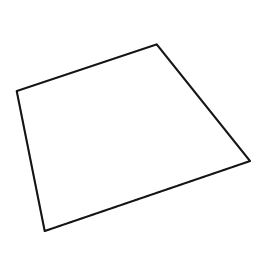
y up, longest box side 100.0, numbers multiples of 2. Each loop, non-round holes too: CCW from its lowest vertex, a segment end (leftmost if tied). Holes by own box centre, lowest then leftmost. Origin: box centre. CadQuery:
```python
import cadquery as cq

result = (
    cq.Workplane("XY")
    .moveTo(-38.0, -40.0)
    .lineTo(50.0, -10.0)
    .lineTo(10.0, 40.0)
    .lineTo(-50.0, 20.0)
    .close()
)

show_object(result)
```